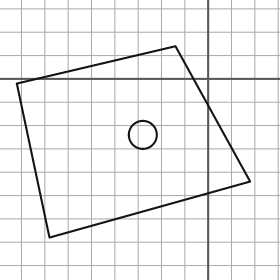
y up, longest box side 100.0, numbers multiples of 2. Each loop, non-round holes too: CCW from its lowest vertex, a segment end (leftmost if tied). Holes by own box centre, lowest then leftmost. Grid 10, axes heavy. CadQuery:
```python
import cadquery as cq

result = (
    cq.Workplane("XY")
    .moveTo(-68.0, -68.0)
    .lineTo(18.0, -44.0)
    .lineTo(-14.0, 14.0)
    .lineTo(-82.0, -2.0)
    .close()
    .moveTo(-28.0, -24.0)
    .circle(6.0)
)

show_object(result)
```